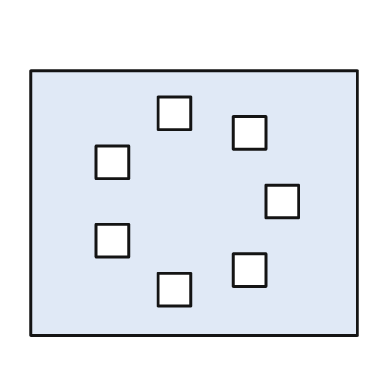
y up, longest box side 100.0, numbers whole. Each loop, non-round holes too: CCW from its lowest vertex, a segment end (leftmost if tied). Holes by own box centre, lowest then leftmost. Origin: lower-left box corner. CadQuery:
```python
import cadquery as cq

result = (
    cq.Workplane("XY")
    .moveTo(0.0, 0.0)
    .lineTo(100.0, 0.0)
    .lineTo(100.0, 81.0)
    .lineTo(0.0, 81.0)
    .close()
    .moveTo(39.0, 9.0)
    .lineTo(49.0, 9.0)
    .lineTo(49.0, 19.0)
    .lineTo(39.0, 19.0)
    .close()
    .moveTo(62.0, 15.0)
    .lineTo(72.0, 15.0)
    .lineTo(72.0, 25.0)
    .lineTo(62.0, 25.0)
    .close()
    .moveTo(20.0, 24.0)
    .lineTo(30.0, 24.0)
    .lineTo(30.0, 34.0)
    .lineTo(20.0, 34.0)
    .close()
    .moveTo(72.0, 36.0)
    .lineTo(82.0, 36.0)
    .lineTo(82.0, 46.0)
    .lineTo(72.0, 46.0)
    .close()
    .moveTo(20.0, 48.0)
    .lineTo(30.0, 48.0)
    .lineTo(30.0, 58.0)
    .lineTo(20.0, 58.0)
    .close()
    .moveTo(62.0, 57.0)
    .lineTo(72.0, 57.0)
    .lineTo(72.0, 67.0)
    .lineTo(62.0, 67.0)
    .close()
    .moveTo(39.0, 63.0)
    .lineTo(49.0, 63.0)
    .lineTo(49.0, 73.0)
    .lineTo(39.0, 73.0)
    .close()
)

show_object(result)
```